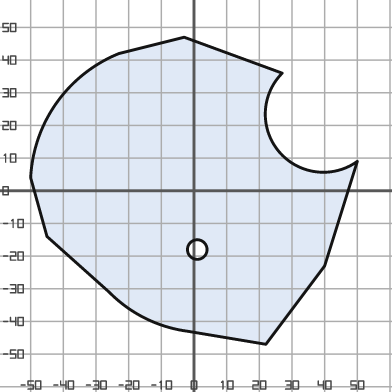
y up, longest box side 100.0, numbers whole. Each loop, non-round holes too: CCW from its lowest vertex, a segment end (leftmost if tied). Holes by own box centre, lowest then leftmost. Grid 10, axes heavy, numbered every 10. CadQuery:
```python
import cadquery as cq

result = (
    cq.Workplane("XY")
    .moveTo(22.0, -47.0)
    .lineTo(40.0, -23.0)
    .lineTo(50.0, 9.0)
    .threePointArc((26.0, 12.0), (27.0, 36.0))
    .lineTo(-3.0, 47.0)
    .lineTo(-23.0, 42.0)
    .threePointArc((-42.0, 27.0), (-50.0, 4.0))
    .lineTo(-45.0, -14.0)
    .lineTo(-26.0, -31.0)
    .threePointArc((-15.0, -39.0), (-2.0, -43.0))
    .close()
    .moveTo(1.0, -18.0)
    .circle(3.0)
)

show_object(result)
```